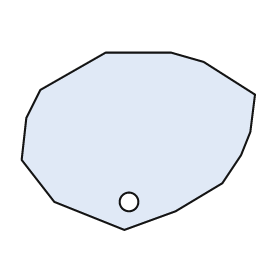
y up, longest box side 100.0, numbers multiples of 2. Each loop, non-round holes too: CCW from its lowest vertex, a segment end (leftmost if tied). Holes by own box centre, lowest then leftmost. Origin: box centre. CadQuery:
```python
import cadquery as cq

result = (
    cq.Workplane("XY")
    .moveTo(-6.0, -38.0)
    .lineTo(16.0, -30.0)
    .lineTo(36.0, -18.0)
    .lineTo(44.0, -6.0)
    .lineTo(48.0, 4.0)
    .lineTo(50.0, 20.0)
    .lineTo(28.0, 34.0)
    .lineTo(14.0, 38.0)
    .lineTo(-14.0, 38.0)
    .lineTo(-42.0, 22.0)
    .lineTo(-48.0, 10.0)
    .lineTo(-50.0, -8.0)
    .lineTo(-36.0, -26.0)
    .close()
    .moveTo(-4.0, -26.0)
    .circle(4.0)
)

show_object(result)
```